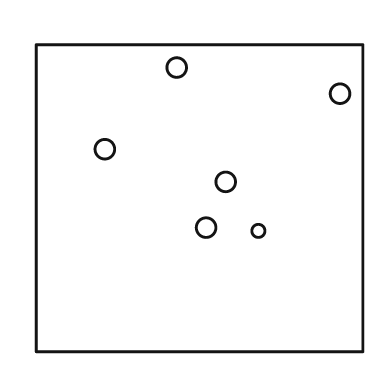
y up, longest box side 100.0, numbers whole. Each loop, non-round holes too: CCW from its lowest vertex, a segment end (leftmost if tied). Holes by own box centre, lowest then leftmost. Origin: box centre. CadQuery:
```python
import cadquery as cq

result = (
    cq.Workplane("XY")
    .moveTo(-50.0, -47.0)
    .lineTo(50.0, -47.0)
    .lineTo(50.0, 47.0)
    .lineTo(-50.0, 47.0)
    .close()
    .moveTo(18.0, -10.0)
    .circle(2.0)
    .moveTo(2.0, -9.0)
    .circle(3.0)
    .moveTo(8.0, 5.0)
    .circle(3.0)
    .moveTo(-29.0, 15.0)
    .circle(3.0)
    .moveTo(43.0, 32.0)
    .circle(3.0)
    .moveTo(-7.0, 40.0)
    .circle(3.0)
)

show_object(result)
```